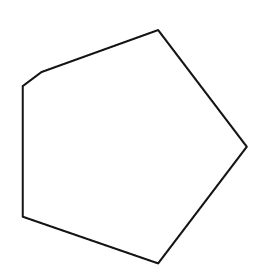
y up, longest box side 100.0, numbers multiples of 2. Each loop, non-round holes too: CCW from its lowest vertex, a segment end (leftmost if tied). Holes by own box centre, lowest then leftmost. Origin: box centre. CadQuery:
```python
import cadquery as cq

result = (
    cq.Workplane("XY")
    .moveTo(10.0, -50.0)
    .lineTo(48.0, 0.0)
    .lineTo(10.0, 50.0)
    .lineTo(-40.0, 32.0)
    .lineTo(-48.0, 26.0)
    .lineTo(-48.0, -30.0)
    .close()
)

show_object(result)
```